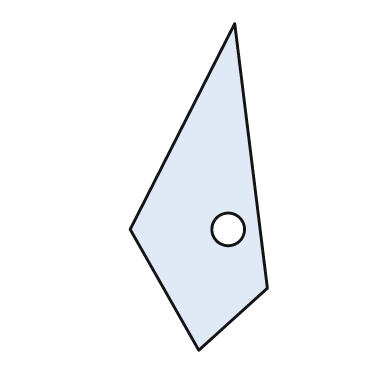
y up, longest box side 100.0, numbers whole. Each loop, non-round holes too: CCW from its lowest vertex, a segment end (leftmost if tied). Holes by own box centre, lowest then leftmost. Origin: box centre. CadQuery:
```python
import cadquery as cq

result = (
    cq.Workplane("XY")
    .moveTo(0.0, -50.0)
    .lineTo(21.0, -31.0)
    .lineTo(11.0, 50.0)
    .lineTo(-21.0, -13.0)
    .close()
    .moveTo(9.0, -13.0)
    .circle(5.0)
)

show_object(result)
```